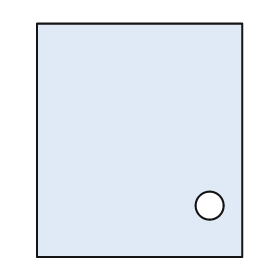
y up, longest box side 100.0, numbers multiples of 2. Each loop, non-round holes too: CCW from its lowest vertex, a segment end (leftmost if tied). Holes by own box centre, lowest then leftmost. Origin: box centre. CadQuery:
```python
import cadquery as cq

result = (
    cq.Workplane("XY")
    .moveTo(-44.0, -50.0)
    .lineTo(44.0, -50.0)
    .lineTo(44.0, 50.0)
    .lineTo(-44.0, 50.0)
    .close()
    .moveTo(30.0, -28.0)
    .circle(6.0)
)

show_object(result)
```